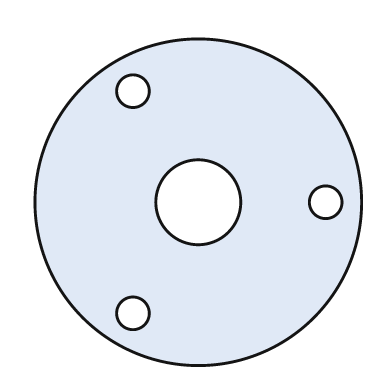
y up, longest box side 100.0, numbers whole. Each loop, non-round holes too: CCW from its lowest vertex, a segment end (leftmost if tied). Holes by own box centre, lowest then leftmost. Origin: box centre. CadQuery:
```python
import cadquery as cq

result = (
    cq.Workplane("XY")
    .moveTo(0.0, 0.0)
    .circle(50.0)
    .moveTo(-20.0, -34.0)
    .circle(5.0)
    .moveTo(0.0, 0.0)
    .circle(13.0)
    .moveTo(39.0, 0.0)
    .circle(5.0)
    .moveTo(-20.0, 34.0)
    .circle(5.0)
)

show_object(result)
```